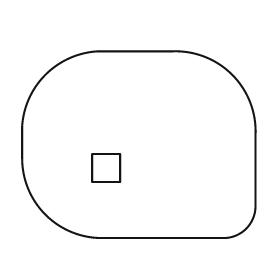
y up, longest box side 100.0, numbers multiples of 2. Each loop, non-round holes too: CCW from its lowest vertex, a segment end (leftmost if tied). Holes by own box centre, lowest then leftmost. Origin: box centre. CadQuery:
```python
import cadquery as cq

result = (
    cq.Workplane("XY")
    .moveTo(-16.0, -40.0)
    .lineTo(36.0, -40.0)
    .threePointArc((46.0, -36.0), (50.0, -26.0))
    .lineTo(50.0, 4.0)
    .threePointArc((40.0, 30.0), (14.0, 40.0))
    .lineTo(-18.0, 40.0)
    .threePointArc((-40.0, 30.0), (-50.0, 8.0))
    .lineTo(-50.0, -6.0)
    .threePointArc((-40.0, -30.0), (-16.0, -40.0))
    .close()
    .moveTo(-20.0, -16.0)
    .lineTo(-8.0, -16.0)
    .lineTo(-8.0, -4.0)
    .lineTo(-20.0, -4.0)
    .close()
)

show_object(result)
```